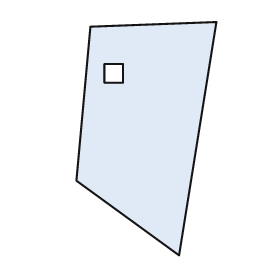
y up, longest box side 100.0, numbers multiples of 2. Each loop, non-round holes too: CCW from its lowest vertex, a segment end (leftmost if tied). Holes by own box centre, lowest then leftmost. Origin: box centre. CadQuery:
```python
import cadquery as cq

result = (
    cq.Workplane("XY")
    .moveTo(14.0, -50.0)
    .lineTo(30.0, 50.0)
    .lineTo(-24.0, 48.0)
    .lineTo(-30.0, -18.0)
    .close()
    .moveTo(-18.0, 24.0)
    .lineTo(-10.0, 24.0)
    .lineTo(-10.0, 32.0)
    .lineTo(-18.0, 32.0)
    .close()
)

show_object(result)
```